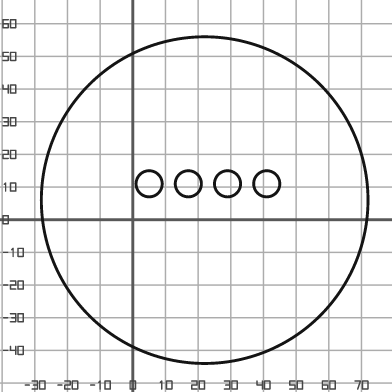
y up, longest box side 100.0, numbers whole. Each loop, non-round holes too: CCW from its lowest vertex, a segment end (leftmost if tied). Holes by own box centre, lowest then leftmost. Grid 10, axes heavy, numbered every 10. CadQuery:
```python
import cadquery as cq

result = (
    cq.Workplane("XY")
    .moveTo(22.0, 6.0)
    .circle(50.0)
    .moveTo(5.0, 11.0)
    .circle(4.0)
    .moveTo(17.0, 11.0)
    .circle(4.0)
    .moveTo(29.0, 11.0)
    .circle(4.0)
    .moveTo(41.0, 11.0)
    .circle(4.0)
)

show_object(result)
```